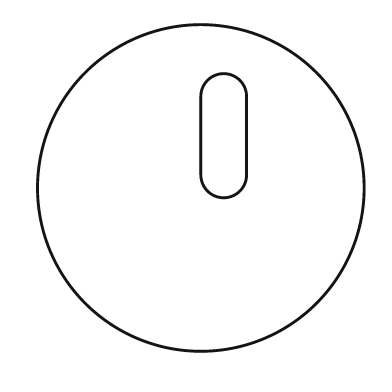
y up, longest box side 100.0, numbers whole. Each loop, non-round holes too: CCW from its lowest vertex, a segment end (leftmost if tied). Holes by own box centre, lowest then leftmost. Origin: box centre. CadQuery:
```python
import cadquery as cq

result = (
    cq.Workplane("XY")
    .moveTo(0.0, 0.0)
    .circle(50.0)
    .moveTo(0.0, 4.0)
    .threePointArc((7.0, -3.0), (14.0, 4.0))
    .lineTo(14.0, 28.0)
    .threePointArc((7.0, 35.0), (0.0, 28.0))
    .close()
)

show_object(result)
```